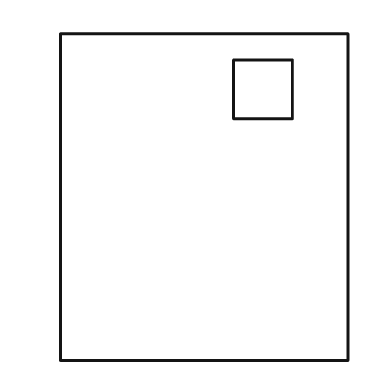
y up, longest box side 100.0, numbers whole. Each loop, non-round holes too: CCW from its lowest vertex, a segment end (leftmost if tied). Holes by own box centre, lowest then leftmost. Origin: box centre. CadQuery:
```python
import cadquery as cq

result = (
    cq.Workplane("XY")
    .moveTo(-44.0, -50.0)
    .lineTo(44.0, -50.0)
    .lineTo(44.0, 50.0)
    .lineTo(-44.0, 50.0)
    .close()
    .moveTo(9.0, 24.0)
    .lineTo(27.0, 24.0)
    .lineTo(27.0, 42.0)
    .lineTo(9.0, 42.0)
    .close()
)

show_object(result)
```